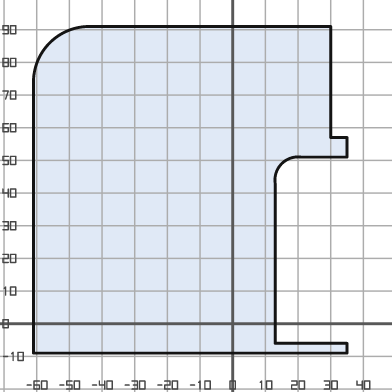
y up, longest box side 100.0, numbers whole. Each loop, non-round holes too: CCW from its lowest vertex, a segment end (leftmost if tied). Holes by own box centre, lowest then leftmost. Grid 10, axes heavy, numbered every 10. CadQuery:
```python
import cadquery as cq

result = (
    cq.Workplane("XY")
    .moveTo(-61.0, -9.0)
    .lineTo(35.0, -9.0)
    .lineTo(35.0, -6.0)
    .lineTo(13.0, -6.0)
    .lineTo(13.0, 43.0)
    .threePointArc((15.0, 49.0), (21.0, 51.0))
    .lineTo(35.0, 51.0)
    .lineTo(35.0, 57.0)
    .lineTo(30.0, 57.0)
    .lineTo(30.0, 91.0)
    .lineTo(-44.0, 91.0)
    .threePointArc((-56.0, 86.0), (-61.0, 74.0))
    .close()
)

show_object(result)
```